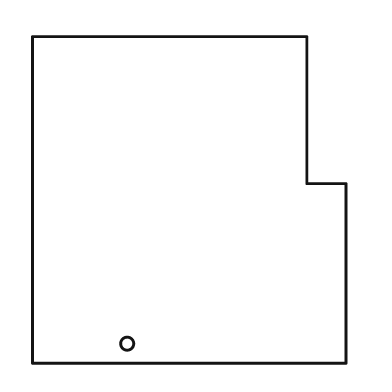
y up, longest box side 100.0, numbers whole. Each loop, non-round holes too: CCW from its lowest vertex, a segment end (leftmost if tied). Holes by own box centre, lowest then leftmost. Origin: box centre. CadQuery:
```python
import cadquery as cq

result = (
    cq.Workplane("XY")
    .moveTo(-48.0, -50.0)
    .lineTo(48.0, -50.0)
    .lineTo(48.0, 5.0)
    .lineTo(36.0, 5.0)
    .lineTo(36.0, 50.0)
    .lineTo(-48.0, 50.0)
    .close()
    .moveTo(-19.0, -44.0)
    .circle(2.0)
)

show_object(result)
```